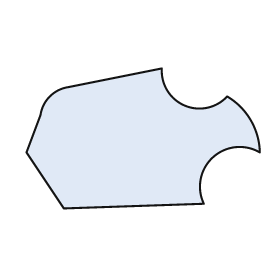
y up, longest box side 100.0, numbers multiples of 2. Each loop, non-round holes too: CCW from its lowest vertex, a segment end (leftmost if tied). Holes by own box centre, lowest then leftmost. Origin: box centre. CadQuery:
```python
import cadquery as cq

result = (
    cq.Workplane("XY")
    .moveTo(-34.0, -30.0)
    .lineTo(26.0, -28.0)
    .threePointArc((30.0, -8.0), (50.0, -6.0))
    .threePointArc((46.0, 8.0), (36.0, 18.0))
    .threePointArc((18.0, 14.0), (8.0, 30.0))
    .lineTo(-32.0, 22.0)
    .threePointArc((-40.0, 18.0), (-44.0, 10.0))
    .lineTo(-50.0, -6.0)
    .close()
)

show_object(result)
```